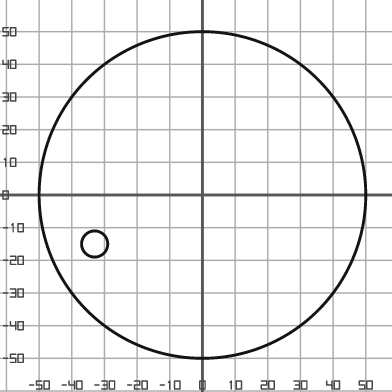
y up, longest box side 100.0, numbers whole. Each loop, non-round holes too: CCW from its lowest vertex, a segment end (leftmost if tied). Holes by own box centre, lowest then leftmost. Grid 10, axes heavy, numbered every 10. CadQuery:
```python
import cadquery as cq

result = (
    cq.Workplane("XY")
    .moveTo(0.0, 0.0)
    .circle(50.0)
    .moveTo(-33.0, -15.0)
    .circle(4.0)
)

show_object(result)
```